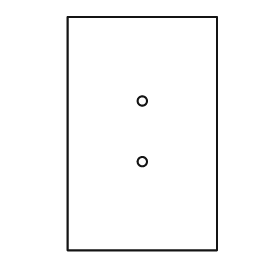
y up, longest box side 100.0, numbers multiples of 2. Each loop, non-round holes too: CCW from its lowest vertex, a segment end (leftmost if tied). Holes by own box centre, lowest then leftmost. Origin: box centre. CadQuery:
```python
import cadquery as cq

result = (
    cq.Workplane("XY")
    .moveTo(-32.0, -50.0)
    .lineTo(32.0, -50.0)
    .lineTo(32.0, 50.0)
    .lineTo(-32.0, 50.0)
    .close()
    .moveTo(0.0, -12.0)
    .circle(2.0)
    .moveTo(0.0, 14.0)
    .circle(2.0)
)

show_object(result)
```